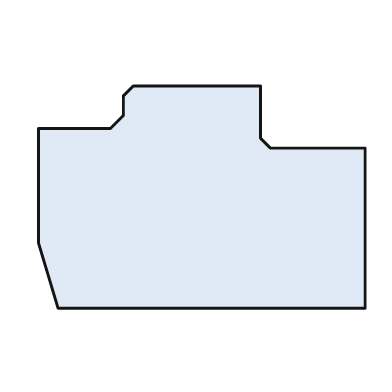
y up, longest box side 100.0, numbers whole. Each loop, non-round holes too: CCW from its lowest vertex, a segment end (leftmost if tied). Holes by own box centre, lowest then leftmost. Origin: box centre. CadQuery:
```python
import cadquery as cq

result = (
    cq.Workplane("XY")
    .moveTo(-44.0, -34.0)
    .lineTo(50.0, -34.0)
    .lineTo(50.0, 15.0)
    .lineTo(21.0, 15.0)
    .lineTo(18.0, 18.0)
    .lineTo(18.0, 34.0)
    .lineTo(-21.0, 34.0)
    .lineTo(-24.0, 31.0)
    .lineTo(-24.0, 25.0)
    .lineTo(-28.0, 21.0)
    .lineTo(-50.0, 21.0)
    .lineTo(-50.0, -14.0)
    .close()
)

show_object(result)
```